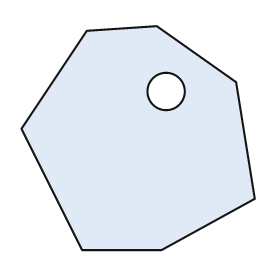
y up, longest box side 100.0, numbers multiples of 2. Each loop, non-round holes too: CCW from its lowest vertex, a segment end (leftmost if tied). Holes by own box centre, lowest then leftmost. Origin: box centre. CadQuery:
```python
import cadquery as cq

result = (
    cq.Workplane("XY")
    .moveTo(-24.0, -48.0)
    .lineTo(10.0, -48.0)
    .lineTo(50.0, -26.0)
    .lineTo(42.0, 24.0)
    .lineTo(8.0, 48.0)
    .lineTo(-22.0, 46.0)
    .lineTo(-50.0, 4.0)
    .close()
    .moveTo(12.0, 20.0)
    .circle(8.0)
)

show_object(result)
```